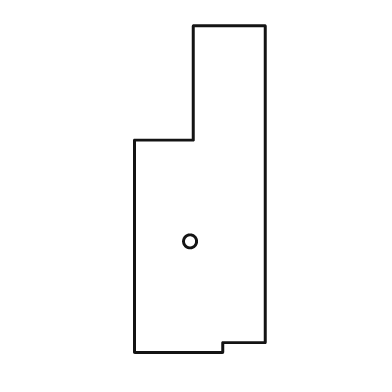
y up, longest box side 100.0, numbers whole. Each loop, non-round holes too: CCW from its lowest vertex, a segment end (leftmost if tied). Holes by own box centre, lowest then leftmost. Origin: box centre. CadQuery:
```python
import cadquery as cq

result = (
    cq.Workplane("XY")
    .moveTo(-20.0, -50.0)
    .lineTo(7.0, -50.0)
    .lineTo(7.0, -47.0)
    .lineTo(20.0, -47.0)
    .lineTo(20.0, 50.0)
    .lineTo(-2.0, 50.0)
    .lineTo(-2.0, 15.0)
    .lineTo(-20.0, 15.0)
    .close()
    .moveTo(-3.0, -16.0)
    .circle(2.0)
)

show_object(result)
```